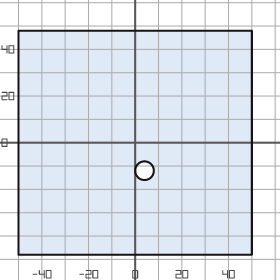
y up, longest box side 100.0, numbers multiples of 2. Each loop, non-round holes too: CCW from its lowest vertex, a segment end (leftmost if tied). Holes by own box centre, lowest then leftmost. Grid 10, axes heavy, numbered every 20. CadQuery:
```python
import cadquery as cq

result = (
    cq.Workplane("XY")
    .moveTo(-50.0, -48.0)
    .lineTo(50.0, -48.0)
    .lineTo(50.0, 48.0)
    .lineTo(-50.0, 48.0)
    .close()
    .moveTo(4.0, -12.0)
    .circle(4.0)
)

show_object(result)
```